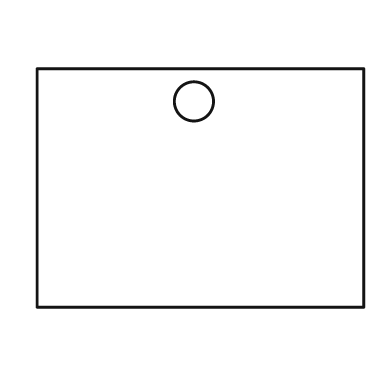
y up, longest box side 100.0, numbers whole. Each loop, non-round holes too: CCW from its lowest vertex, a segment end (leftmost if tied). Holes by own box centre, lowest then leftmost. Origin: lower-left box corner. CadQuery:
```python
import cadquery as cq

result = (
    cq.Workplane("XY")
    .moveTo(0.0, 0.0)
    .lineTo(100.0, 0.0)
    .lineTo(100.0, 73.0)
    .lineTo(0.0, 73.0)
    .close()
    .moveTo(48.0, 63.0)
    .circle(6.0)
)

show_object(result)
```